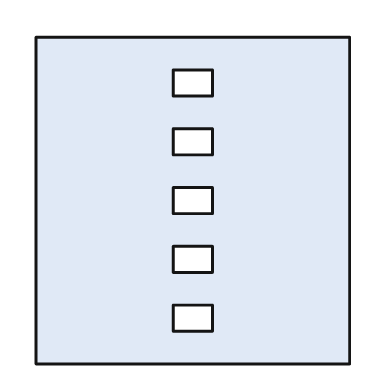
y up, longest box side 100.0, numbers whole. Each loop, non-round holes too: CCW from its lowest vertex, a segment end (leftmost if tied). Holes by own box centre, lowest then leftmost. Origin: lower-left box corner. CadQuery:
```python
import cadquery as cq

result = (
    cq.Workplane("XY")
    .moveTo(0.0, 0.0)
    .lineTo(96.0, 0.0)
    .lineTo(96.0, 100.0)
    .lineTo(0.0, 100.0)
    .close()
    .moveTo(42.0, 10.0)
    .lineTo(54.0, 10.0)
    .lineTo(54.0, 18.0)
    .lineTo(42.0, 18.0)
    .close()
    .moveTo(42.0, 28.0)
    .lineTo(54.0, 28.0)
    .lineTo(54.0, 36.0)
    .lineTo(42.0, 36.0)
    .close()
    .moveTo(42.0, 46.0)
    .lineTo(54.0, 46.0)
    .lineTo(54.0, 54.0)
    .lineTo(42.0, 54.0)
    .close()
    .moveTo(42.0, 64.0)
    .lineTo(54.0, 64.0)
    .lineTo(54.0, 72.0)
    .lineTo(42.0, 72.0)
    .close()
    .moveTo(42.0, 82.0)
    .lineTo(54.0, 82.0)
    .lineTo(54.0, 90.0)
    .lineTo(42.0, 90.0)
    .close()
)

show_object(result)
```